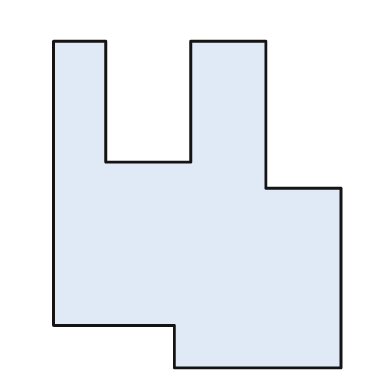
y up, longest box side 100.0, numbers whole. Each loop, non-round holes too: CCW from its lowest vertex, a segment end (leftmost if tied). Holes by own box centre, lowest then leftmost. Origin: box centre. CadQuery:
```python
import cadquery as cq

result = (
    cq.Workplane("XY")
    .moveTo(-7.0, -50.0)
    .lineTo(44.0, -50.0)
    .lineTo(44.0, 5.0)
    .lineTo(21.0, 5.0)
    .lineTo(21.0, 50.0)
    .lineTo(-2.0, 50.0)
    .lineTo(-2.0, 13.0)
    .lineTo(-28.0, 13.0)
    .lineTo(-28.0, 50.0)
    .lineTo(-44.0, 50.0)
    .lineTo(-44.0, -37.0)
    .lineTo(-7.0, -37.0)
    .close()
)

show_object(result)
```